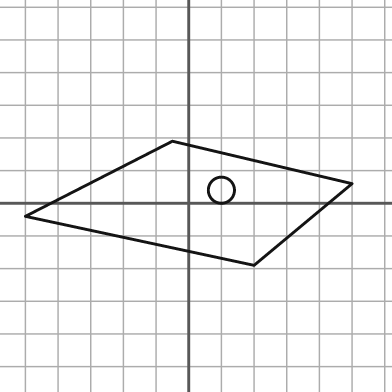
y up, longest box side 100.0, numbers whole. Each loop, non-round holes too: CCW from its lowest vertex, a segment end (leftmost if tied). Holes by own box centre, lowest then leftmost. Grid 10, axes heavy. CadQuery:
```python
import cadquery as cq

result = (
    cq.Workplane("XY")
    .moveTo(20.0, -19.0)
    .lineTo(50.0, 6.0)
    .lineTo(-5.0, 19.0)
    .lineTo(-50.0, -4.0)
    .close()
    .moveTo(10.0, 4.0)
    .circle(4.0)
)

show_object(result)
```